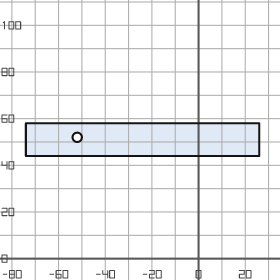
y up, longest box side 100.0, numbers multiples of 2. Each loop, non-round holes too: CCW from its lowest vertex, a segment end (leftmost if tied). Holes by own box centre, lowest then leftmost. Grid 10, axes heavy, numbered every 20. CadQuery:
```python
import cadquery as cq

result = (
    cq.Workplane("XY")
    .moveTo(-74.0, 44.0)
    .lineTo(26.0, 44.0)
    .lineTo(26.0, 58.0)
    .lineTo(-74.0, 58.0)
    .close()
    .moveTo(-52.0, 52.0)
    .circle(2.0)
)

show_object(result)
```